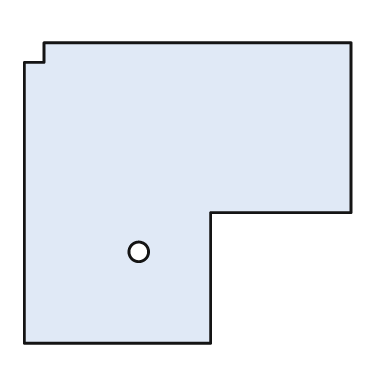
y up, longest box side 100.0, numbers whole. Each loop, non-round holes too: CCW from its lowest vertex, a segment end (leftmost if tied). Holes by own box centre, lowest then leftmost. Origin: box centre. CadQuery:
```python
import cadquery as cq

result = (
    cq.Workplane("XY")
    .moveTo(-50.0, -46.0)
    .lineTo(7.0, -46.0)
    .lineTo(7.0, -6.0)
    .lineTo(50.0, -6.0)
    .lineTo(50.0, 46.0)
    .lineTo(-44.0, 46.0)
    .lineTo(-44.0, 40.0)
    .lineTo(-50.0, 40.0)
    .close()
    .moveTo(-15.0, -18.0)
    .circle(3.0)
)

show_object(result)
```